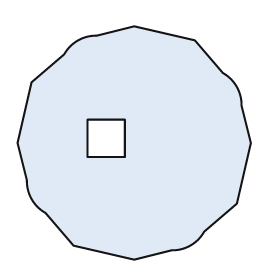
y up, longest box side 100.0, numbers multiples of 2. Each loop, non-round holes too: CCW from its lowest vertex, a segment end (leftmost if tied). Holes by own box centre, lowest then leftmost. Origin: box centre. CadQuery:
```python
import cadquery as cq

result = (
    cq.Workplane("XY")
    .moveTo(0.0, -50.0)
    .lineTo(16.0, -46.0)
    .threePointArc((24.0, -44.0), (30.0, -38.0))
    .lineTo(44.0, -26.0)
    .lineTo(50.0, 0.0)
    .lineTo(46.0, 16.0)
    .threePointArc((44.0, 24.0), (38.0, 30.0))
    .lineTo(26.0, 44.0)
    .lineTo(0.0, 50.0)
    .lineTo(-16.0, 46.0)
    .threePointArc((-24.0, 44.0), (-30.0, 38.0))
    .lineTo(-44.0, 26.0)
    .lineTo(-50.0, 0.0)
    .lineTo(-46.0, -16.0)
    .threePointArc((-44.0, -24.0), (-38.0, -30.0))
    .lineTo(-26.0, -44.0)
    .close()
    .moveTo(-20.0, -6.0)
    .lineTo(-4.0, -6.0)
    .lineTo(-4.0, 10.0)
    .lineTo(-20.0, 10.0)
    .close()
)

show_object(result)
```